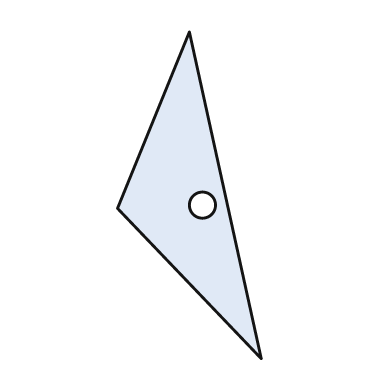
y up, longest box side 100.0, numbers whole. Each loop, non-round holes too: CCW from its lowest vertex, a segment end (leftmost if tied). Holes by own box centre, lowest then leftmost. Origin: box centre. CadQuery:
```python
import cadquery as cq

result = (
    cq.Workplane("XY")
    .moveTo(22.0, -50.0)
    .lineTo(0.0, 50.0)
    .lineTo(-22.0, -4.0)
    .close()
    .moveTo(4.0, -3.0)
    .circle(4.0)
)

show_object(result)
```